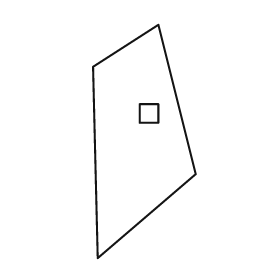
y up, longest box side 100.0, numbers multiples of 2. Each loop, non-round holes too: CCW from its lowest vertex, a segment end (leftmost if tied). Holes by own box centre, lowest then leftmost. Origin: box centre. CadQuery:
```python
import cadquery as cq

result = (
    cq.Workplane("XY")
    .moveTo(-20.0, -50.0)
    .lineTo(22.0, -14.0)
    .lineTo(6.0, 50.0)
    .lineTo(-22.0, 32.0)
    .close()
    .moveTo(-2.0, 8.0)
    .lineTo(6.0, 8.0)
    .lineTo(6.0, 16.0)
    .lineTo(-2.0, 16.0)
    .close()
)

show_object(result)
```